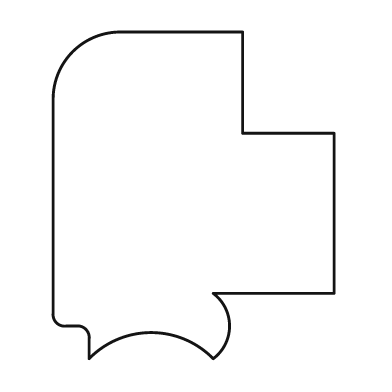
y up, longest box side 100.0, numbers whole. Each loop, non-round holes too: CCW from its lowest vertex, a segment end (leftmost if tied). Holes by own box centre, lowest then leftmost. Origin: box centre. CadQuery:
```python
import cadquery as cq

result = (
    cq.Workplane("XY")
    .moveTo(-32.0, -50.0)
    .threePointArc((-13.0, -42.0), (6.0, -50.0))
    .threePointArc((11.0, -40.0), (6.0, -30.0))
    .lineTo(43.0, -30.0)
    .lineTo(43.0, 19.0)
    .lineTo(15.0, 19.0)
    .lineTo(15.0, 50.0)
    .lineTo(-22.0, 50.0)
    .threePointArc((-37.0, 44.0), (-43.0, 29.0))
    .lineTo(-43.0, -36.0)
    .threePointArc((-42.0, -39.0), (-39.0, -40.0))
    .lineTo(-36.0, -40.0)
    .threePointArc((-33.0, -41.0), (-32.0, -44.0))
    .close()
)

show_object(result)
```